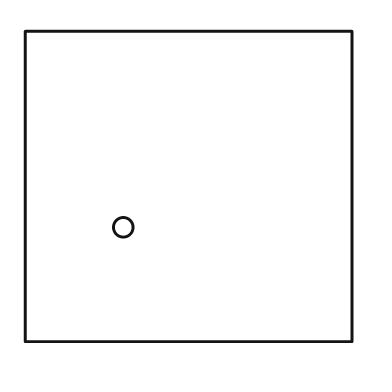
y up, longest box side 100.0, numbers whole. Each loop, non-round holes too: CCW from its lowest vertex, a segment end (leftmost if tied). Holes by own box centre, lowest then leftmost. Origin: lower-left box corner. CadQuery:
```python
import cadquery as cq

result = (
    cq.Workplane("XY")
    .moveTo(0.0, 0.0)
    .lineTo(100.0, 0.0)
    .lineTo(100.0, 95.0)
    .lineTo(0.0, 95.0)
    .close()
    .moveTo(30.0, 35.0)
    .circle(3.0)
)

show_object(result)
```